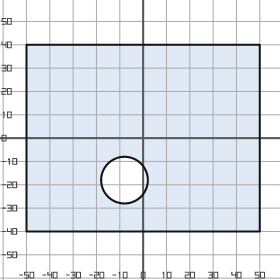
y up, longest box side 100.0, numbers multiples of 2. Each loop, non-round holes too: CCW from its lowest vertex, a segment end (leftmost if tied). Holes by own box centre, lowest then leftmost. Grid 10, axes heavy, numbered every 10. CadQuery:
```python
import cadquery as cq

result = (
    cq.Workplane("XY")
    .moveTo(-50.0, -40.0)
    .lineTo(50.0, -40.0)
    .lineTo(50.0, 40.0)
    .lineTo(-50.0, 40.0)
    .close()
    .moveTo(-8.0, -18.0)
    .circle(10.0)
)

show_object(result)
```